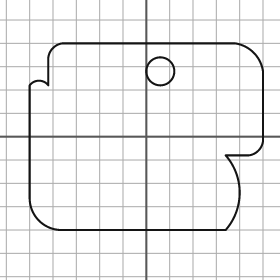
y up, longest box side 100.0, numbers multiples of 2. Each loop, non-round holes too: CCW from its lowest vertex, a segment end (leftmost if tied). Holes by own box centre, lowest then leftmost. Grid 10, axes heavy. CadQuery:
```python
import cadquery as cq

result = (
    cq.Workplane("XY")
    .moveTo(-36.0, -40.0)
    .lineTo(34.0, -40.0)
    .threePointArc((40.0, -24.0), (34.0, -8.0))
    .lineTo(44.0, -8.0)
    .threePointArc((48.0, -6.0), (50.0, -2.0))
    .lineTo(50.0, 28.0)
    .threePointArc((46.0, 36.0), (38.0, 40.0))
    .lineTo(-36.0, 40.0)
    .threePointArc((-40.0, 38.0), (-42.0, 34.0))
    .lineTo(-42.0, 22.0)
    .threePointArc((-46.0, 24.0), (-50.0, 22.0))
    .lineTo(-50.0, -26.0)
    .threePointArc((-46.0, -36.0), (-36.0, -40.0))
    .close()
    .moveTo(6.0, 28.0)
    .circle(6.0)
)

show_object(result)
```